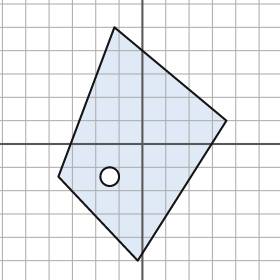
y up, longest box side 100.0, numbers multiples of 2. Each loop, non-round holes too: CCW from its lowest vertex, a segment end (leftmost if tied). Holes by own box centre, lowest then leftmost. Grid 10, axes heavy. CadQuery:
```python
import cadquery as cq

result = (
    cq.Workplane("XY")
    .moveTo(-2.0, -50.0)
    .lineTo(36.0, 10.0)
    .lineTo(-12.0, 50.0)
    .lineTo(-36.0, -14.0)
    .close()
    .moveTo(-14.0, -14.0)
    .circle(4.0)
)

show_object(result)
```